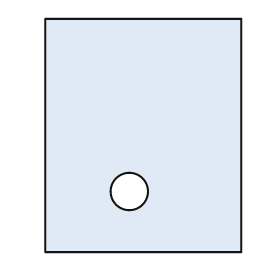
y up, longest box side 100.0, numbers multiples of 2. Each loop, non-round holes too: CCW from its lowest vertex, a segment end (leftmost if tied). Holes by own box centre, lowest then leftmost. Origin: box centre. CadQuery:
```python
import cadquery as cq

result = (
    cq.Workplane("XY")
    .moveTo(-42.0, -50.0)
    .lineTo(42.0, -50.0)
    .lineTo(42.0, 50.0)
    .lineTo(-42.0, 50.0)
    .close()
    .moveTo(-6.0, -24.0)
    .circle(8.0)
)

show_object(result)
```